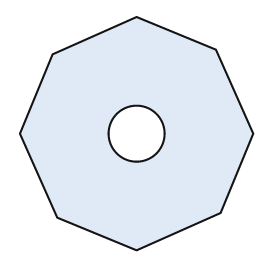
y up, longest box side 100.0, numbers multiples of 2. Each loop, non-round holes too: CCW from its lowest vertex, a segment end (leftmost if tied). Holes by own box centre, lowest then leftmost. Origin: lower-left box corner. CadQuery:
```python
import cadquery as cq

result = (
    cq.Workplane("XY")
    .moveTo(50.0, 0.0)
    .lineTo(86.0, 16.0)
    .lineTo(100.0, 50.0)
    .lineTo(84.0, 86.0)
    .lineTo(50.0, 100.0)
    .lineTo(14.0, 84.0)
    .lineTo(0.0, 50.0)
    .lineTo(16.0, 14.0)
    .close()
    .moveTo(50.0, 50.0)
    .circle(12.0)
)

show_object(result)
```